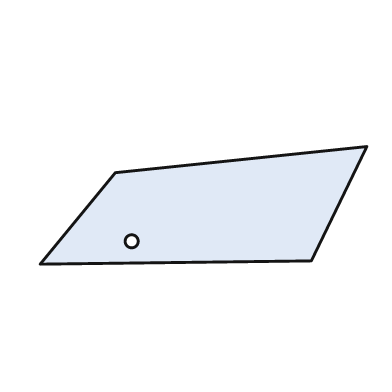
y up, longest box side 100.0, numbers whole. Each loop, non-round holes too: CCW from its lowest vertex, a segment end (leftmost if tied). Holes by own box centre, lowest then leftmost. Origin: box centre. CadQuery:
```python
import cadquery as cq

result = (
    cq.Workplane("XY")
    .moveTo(-50.0, -18.0)
    .lineTo(33.0, -17.0)
    .lineTo(50.0, 18.0)
    .lineTo(-27.0, 10.0)
    .close()
    .moveTo(-22.0, -11.0)
    .circle(2.0)
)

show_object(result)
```